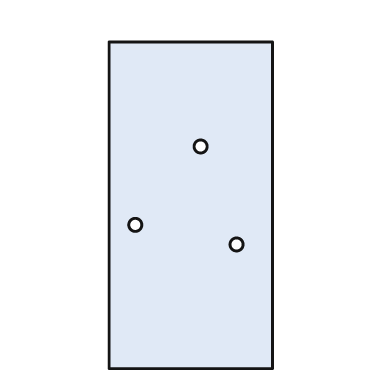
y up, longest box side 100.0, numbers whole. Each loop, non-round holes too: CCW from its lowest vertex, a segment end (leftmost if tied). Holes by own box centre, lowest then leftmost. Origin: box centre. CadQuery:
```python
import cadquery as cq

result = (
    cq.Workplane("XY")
    .moveTo(-25.0, -50.0)
    .lineTo(25.0, -50.0)
    .lineTo(25.0, 50.0)
    .lineTo(-25.0, 50.0)
    .close()
    .moveTo(14.0, -12.0)
    .circle(2.0)
    .moveTo(-17.0, -6.0)
    .circle(2.0)
    .moveTo(3.0, 18.0)
    .circle(2.0)
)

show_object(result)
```